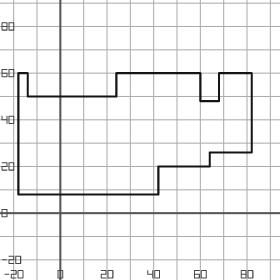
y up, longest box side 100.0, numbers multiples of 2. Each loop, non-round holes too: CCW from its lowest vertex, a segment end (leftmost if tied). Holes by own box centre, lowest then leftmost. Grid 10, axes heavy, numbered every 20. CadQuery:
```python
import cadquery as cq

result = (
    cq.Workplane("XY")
    .moveTo(-18.0, 8.0)
    .lineTo(42.0, 8.0)
    .lineTo(42.0, 20.0)
    .lineTo(64.0, 20.0)
    .lineTo(64.0, 26.0)
    .lineTo(82.0, 26.0)
    .lineTo(82.0, 60.0)
    .lineTo(68.0, 60.0)
    .lineTo(68.0, 48.0)
    .lineTo(60.0, 48.0)
    .lineTo(60.0, 60.0)
    .lineTo(24.0, 60.0)
    .lineTo(24.0, 50.0)
    .lineTo(-14.0, 50.0)
    .lineTo(-14.0, 60.0)
    .lineTo(-18.0, 60.0)
    .close()
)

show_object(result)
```